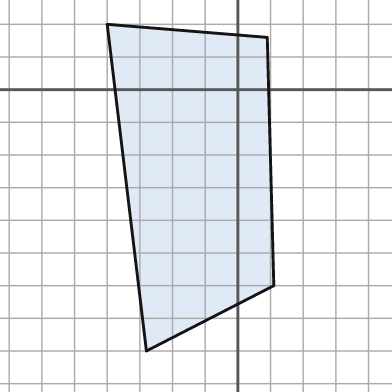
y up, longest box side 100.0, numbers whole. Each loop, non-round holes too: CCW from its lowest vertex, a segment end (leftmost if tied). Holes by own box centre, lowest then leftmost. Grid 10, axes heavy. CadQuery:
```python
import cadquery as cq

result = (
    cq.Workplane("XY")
    .moveTo(-28.0, -80.0)
    .lineTo(11.0, -60.0)
    .lineTo(9.0, 16.0)
    .lineTo(-40.0, 20.0)
    .close()
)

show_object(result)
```